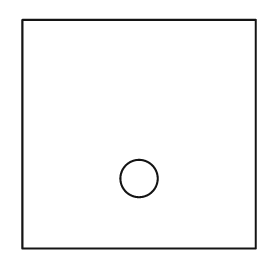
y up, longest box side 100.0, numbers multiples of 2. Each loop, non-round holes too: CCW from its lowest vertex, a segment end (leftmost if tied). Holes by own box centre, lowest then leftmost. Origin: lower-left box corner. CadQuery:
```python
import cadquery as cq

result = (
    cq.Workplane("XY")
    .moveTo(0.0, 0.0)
    .lineTo(100.0, 0.0)
    .lineTo(100.0, 98.0)
    .lineTo(0.0, 98.0)
    .close()
    .moveTo(50.0, 30.0)
    .circle(8.0)
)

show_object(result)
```